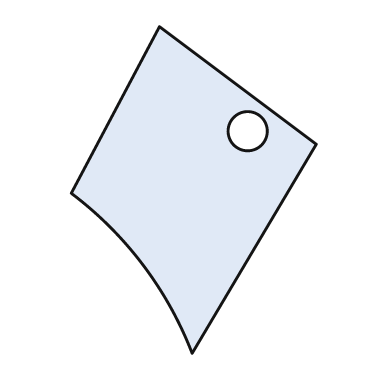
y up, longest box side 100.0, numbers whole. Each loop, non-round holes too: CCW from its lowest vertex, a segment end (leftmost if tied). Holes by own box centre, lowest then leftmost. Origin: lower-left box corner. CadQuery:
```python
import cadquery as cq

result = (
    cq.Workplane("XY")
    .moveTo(37.0, 0.0)
    .lineTo(75.0, 64.0)
    .lineTo(27.0, 100.0)
    .lineTo(0.0, 49.0)
    .threePointArc((22.0, 27.0), (37.0, 0.0))
    .close()
    .moveTo(54.0, 68.0)
    .circle(6.0)
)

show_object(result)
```